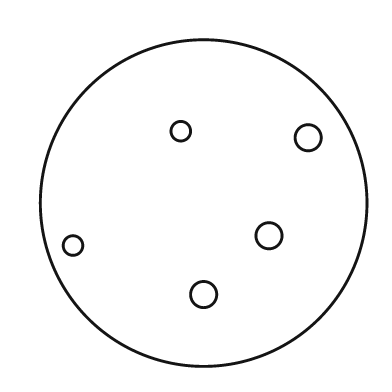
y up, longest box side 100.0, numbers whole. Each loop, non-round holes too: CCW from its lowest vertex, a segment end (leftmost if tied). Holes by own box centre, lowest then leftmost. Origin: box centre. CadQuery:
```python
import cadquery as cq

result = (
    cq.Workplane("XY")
    .moveTo(0.0, 0.0)
    .circle(50.0)
    .moveTo(0.0, -28.0)
    .circle(4.0)
    .moveTo(-40.0, -13.0)
    .circle(3.0)
    .moveTo(20.0, -10.0)
    .circle(4.0)
    .moveTo(32.0, 20.0)
    .circle(4.0)
    .moveTo(-7.0, 22.0)
    .circle(3.0)
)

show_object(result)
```